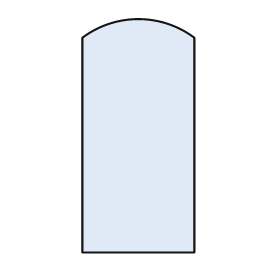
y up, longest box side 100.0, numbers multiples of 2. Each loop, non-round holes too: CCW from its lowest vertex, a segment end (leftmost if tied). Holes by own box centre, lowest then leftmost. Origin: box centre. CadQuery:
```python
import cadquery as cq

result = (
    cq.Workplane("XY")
    .moveTo(-24.0, -50.0)
    .lineTo(24.0, -50.0)
    .lineTo(24.0, 42.0)
    .threePointArc((0.0, 50.0), (-24.0, 42.0))
    .close()
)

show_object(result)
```